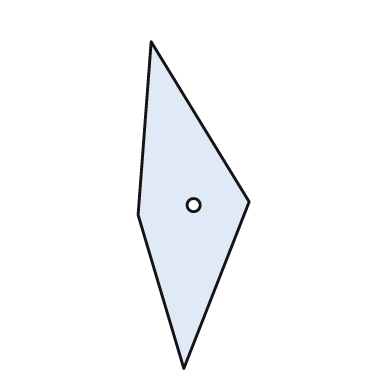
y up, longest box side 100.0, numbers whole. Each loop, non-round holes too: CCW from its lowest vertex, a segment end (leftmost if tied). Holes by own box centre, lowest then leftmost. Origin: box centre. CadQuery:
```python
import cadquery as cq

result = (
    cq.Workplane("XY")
    .moveTo(-3.0, -50.0)
    .lineTo(17.0, 1.0)
    .lineTo(-13.0, 50.0)
    .lineTo(-17.0, -3.0)
    .close()
    .moveTo(0.0, 0.0)
    .circle(2.0)
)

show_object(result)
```